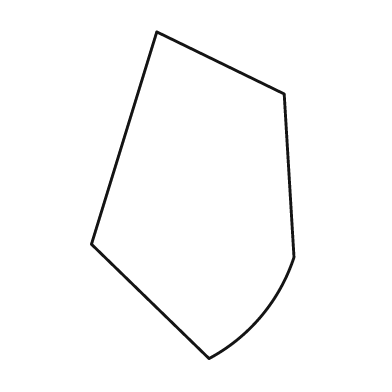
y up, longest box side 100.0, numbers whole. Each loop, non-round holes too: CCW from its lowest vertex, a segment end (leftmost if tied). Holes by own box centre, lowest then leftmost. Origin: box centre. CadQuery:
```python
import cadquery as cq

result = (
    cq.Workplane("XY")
    .moveTo(5.0, -50.0)
    .threePointArc((21.0, -37.0), (31.0, -19.0))
    .lineTo(28.0, 31.0)
    .lineTo(-11.0, 50.0)
    .lineTo(-31.0, -15.0)
    .close()
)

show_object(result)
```